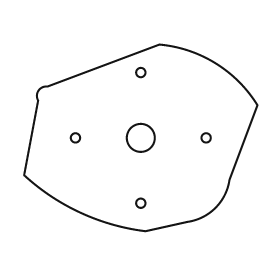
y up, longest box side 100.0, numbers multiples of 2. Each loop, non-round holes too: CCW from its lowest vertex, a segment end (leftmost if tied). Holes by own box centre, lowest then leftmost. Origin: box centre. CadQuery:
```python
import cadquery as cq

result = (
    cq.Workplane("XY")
    .moveTo(2.0, -40.0)
    .lineTo(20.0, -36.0)
    .threePointArc((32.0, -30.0), (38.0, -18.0))
    .lineTo(50.0, 14.0)
    .threePointArc((32.0, 32.0), (8.0, 40.0))
    .lineTo(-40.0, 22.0)
    .threePointArc((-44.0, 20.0), (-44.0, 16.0))
    .lineTo(-50.0, -16.0)
    .threePointArc((-26.0, -32.0), (2.0, -40.0))
    .close()
    .moveTo(0.0, -28.0)
    .circle(2.0)
    .moveTo(-28.0, 0.0)
    .circle(2.0)
    .moveTo(0.0, 0.0)
    .circle(6.0)
    .moveTo(28.0, 0.0)
    .circle(2.0)
    .moveTo(0.0, 28.0)
    .circle(2.0)
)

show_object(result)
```